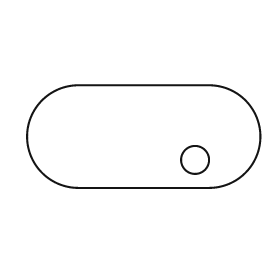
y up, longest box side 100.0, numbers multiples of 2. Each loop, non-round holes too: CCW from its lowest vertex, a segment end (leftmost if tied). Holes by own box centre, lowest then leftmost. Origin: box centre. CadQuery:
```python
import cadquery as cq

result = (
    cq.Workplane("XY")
    .moveTo(-28.0, -22.0)
    .lineTo(28.0, -22.0)
    .threePointArc((50.0, 0.0), (28.0, 22.0))
    .lineTo(-28.0, 22.0)
    .threePointArc((-50.0, 0.0), (-28.0, -22.0))
    .close()
    .moveTo(22.0, -10.0)
    .circle(6.0)
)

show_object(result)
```